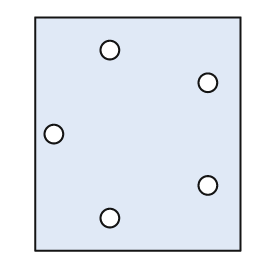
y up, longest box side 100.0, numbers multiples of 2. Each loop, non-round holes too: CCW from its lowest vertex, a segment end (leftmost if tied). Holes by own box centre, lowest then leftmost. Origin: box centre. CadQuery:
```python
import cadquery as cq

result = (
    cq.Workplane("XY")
    .moveTo(-44.0, -50.0)
    .lineTo(44.0, -50.0)
    .lineTo(44.0, 50.0)
    .lineTo(-44.0, 50.0)
    .close()
    .moveTo(-12.0, -36.0)
    .circle(4.0)
    .moveTo(30.0, -22.0)
    .circle(4.0)
    .moveTo(-36.0, 0.0)
    .circle(4.0)
    .moveTo(30.0, 22.0)
    .circle(4.0)
    .moveTo(-12.0, 36.0)
    .circle(4.0)
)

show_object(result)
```